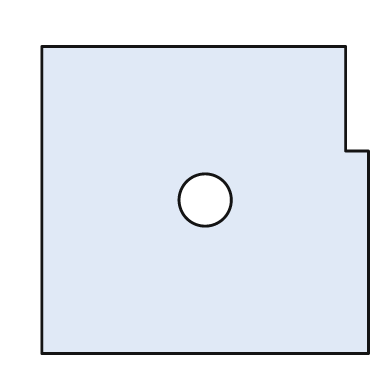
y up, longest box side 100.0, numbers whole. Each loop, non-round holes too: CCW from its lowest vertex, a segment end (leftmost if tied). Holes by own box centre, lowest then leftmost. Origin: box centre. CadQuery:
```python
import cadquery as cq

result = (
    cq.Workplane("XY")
    .moveTo(-50.0, -47.0)
    .lineTo(50.0, -47.0)
    .lineTo(50.0, 15.0)
    .lineTo(43.0, 15.0)
    .lineTo(43.0, 47.0)
    .lineTo(-50.0, 47.0)
    .close()
    .moveTo(0.0, 0.0)
    .circle(8.0)
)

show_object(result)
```